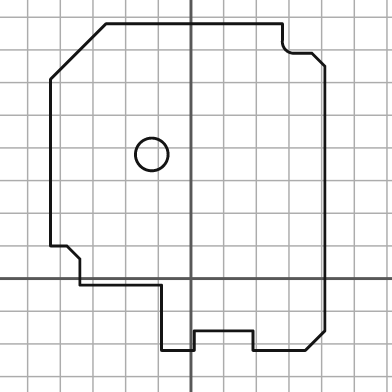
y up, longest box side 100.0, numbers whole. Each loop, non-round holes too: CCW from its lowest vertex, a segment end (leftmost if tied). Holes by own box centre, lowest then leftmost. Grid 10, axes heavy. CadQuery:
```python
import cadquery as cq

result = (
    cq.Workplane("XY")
    .moveTo(-9.0, -22.0)
    .lineTo(1.0, -22.0)
    .lineTo(1.0, -16.0)
    .lineTo(19.0, -16.0)
    .lineTo(19.0, -22.0)
    .lineTo(35.0, -22.0)
    .lineTo(41.0, -16.0)
    .lineTo(41.0, 65.0)
    .lineTo(37.0, 69.0)
    .lineTo(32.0, 69.0)
    .threePointArc((29.0, 70.0), (28.0, 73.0))
    .lineTo(28.0, 78.0)
    .lineTo(-26.0, 78.0)
    .lineTo(-43.0, 61.0)
    .lineTo(-43.0, 10.0)
    .lineTo(-38.0, 10.0)
    .lineTo(-34.0, 6.0)
    .lineTo(-34.0, -2.0)
    .lineTo(-9.0, -2.0)
    .close()
    .moveTo(-12.0, 38.0)
    .circle(5.0)
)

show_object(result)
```